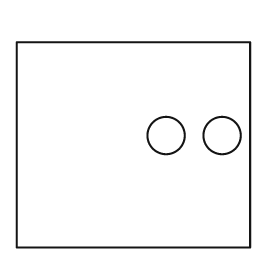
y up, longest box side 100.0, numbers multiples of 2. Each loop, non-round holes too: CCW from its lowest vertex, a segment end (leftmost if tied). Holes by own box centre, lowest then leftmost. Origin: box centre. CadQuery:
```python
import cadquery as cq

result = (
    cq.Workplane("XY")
    .moveTo(-50.0, -44.0)
    .lineTo(50.0, -44.0)
    .lineTo(50.0, 44.0)
    .lineTo(-50.0, 44.0)
    .close()
    .moveTo(14.0, 4.0)
    .circle(8.0)
    .moveTo(38.0, 4.0)
    .circle(8.0)
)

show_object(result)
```